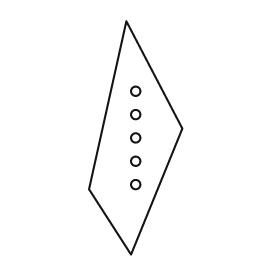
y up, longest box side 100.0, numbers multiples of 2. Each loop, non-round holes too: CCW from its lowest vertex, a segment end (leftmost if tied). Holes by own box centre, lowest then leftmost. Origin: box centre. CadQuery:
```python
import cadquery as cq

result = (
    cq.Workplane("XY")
    .moveTo(-2.0, -50.0)
    .lineTo(20.0, 4.0)
    .lineTo(-4.0, 50.0)
    .lineTo(-20.0, -22.0)
    .close()
    .moveTo(0.0, -20.0)
    .circle(2.0)
    .moveTo(0.0, -10.0)
    .circle(2.0)
    .moveTo(0.0, 0.0)
    .circle(2.0)
    .moveTo(0.0, 10.0)
    .circle(2.0)
    .moveTo(0.0, 20.0)
    .circle(2.0)
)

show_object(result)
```